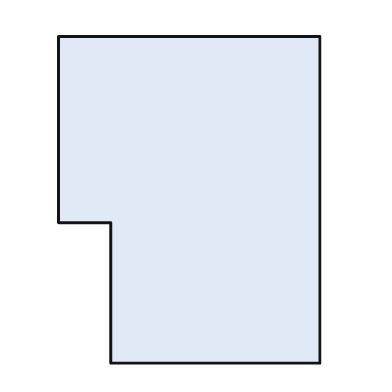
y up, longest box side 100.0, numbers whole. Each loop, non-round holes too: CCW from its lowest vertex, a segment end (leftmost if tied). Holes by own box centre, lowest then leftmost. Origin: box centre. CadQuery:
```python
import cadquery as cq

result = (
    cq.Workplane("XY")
    .moveTo(-24.0, -50.0)
    .lineTo(40.0, -50.0)
    .lineTo(40.0, 50.0)
    .lineTo(-40.0, 50.0)
    .lineTo(-40.0, -7.0)
    .lineTo(-24.0, -7.0)
    .close()
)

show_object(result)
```